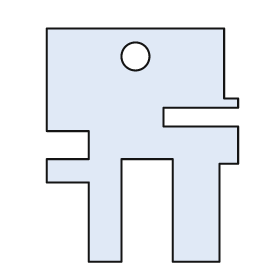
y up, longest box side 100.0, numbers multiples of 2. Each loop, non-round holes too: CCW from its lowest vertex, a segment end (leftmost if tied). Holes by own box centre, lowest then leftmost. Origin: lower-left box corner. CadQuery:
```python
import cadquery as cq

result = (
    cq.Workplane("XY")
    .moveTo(18.0, 0.0)
    .lineTo(32.0, 0.0)
    .lineTo(32.0, 44.0)
    .lineTo(54.0, 44.0)
    .lineTo(54.0, 0.0)
    .lineTo(74.0, 0.0)
    .lineTo(74.0, 42.0)
    .lineTo(82.0, 42.0)
    .lineTo(82.0, 58.0)
    .lineTo(50.0, 58.0)
    .lineTo(50.0, 66.0)
    .lineTo(82.0, 66.0)
    .lineTo(82.0, 70.0)
    .lineTo(76.0, 70.0)
    .lineTo(76.0, 100.0)
    .lineTo(0.0, 100.0)
    .lineTo(0.0, 56.0)
    .lineTo(18.0, 56.0)
    .lineTo(18.0, 44.0)
    .lineTo(0.0, 44.0)
    .lineTo(0.0, 34.0)
    .lineTo(18.0, 34.0)
    .close()
    .moveTo(38.0, 88.0)
    .circle(6.0)
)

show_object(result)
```